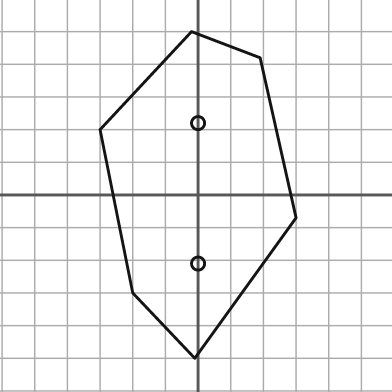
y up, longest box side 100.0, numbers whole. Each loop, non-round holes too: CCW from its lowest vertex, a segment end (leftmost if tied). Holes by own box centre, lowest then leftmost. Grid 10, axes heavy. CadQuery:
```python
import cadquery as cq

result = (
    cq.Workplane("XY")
    .moveTo(-1.0, -50.0)
    .lineTo(30.0, -7.0)
    .lineTo(19.0, 42.0)
    .lineTo(-2.0, 50.0)
    .lineTo(-30.0, 20.0)
    .lineTo(-20.0, -30.0)
    .close()
    .moveTo(0.0, -21.0)
    .circle(2.0)
    .moveTo(0.0, 22.0)
    .circle(2.0)
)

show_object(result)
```